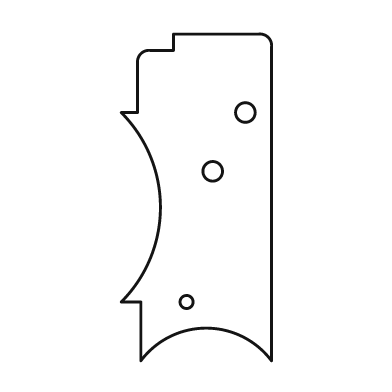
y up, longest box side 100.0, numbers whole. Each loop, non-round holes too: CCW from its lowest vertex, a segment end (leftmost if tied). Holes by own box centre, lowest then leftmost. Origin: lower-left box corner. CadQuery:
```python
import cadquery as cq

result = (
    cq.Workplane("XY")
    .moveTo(6.0, 0.0)
    .threePointArc((26.0, 10.0), (46.0, 0.0))
    .lineTo(46.0, 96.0)
    .threePointArc((45.0, 99.0), (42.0, 100.0))
    .lineTo(16.0, 100.0)
    .lineTo(16.0, 95.0)
    .lineTo(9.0, 95.0)
    .threePointArc((6.0, 94.0), (5.0, 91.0))
    .lineTo(5.0, 76.0)
    .lineTo(0.0, 76.0)
    .threePointArc((12.0, 47.0), (0.0, 18.0))
    .lineTo(6.0, 18.0)
    .close()
    .moveTo(20.0, 18.0)
    .circle(2.0)
    .moveTo(28.0, 58.0)
    .circle(3.0)
    .moveTo(38.0, 76.0)
    .circle(3.0)
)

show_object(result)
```